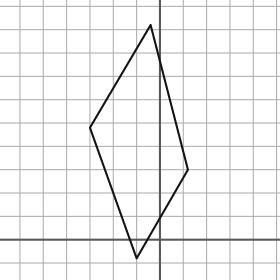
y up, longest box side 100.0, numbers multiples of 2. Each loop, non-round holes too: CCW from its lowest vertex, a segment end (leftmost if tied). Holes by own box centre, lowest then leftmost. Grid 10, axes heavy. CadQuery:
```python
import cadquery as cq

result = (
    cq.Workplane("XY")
    .moveTo(-10.0, -8.0)
    .lineTo(12.0, 30.0)
    .lineTo(-4.0, 92.0)
    .lineTo(-30.0, 48.0)
    .close()
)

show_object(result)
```